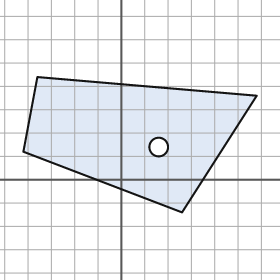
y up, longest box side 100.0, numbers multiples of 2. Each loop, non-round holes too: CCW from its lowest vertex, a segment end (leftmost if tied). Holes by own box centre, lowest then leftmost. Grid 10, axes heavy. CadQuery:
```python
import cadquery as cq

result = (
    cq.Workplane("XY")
    .moveTo(26.0, -14.0)
    .lineTo(58.0, 36.0)
    .lineTo(-36.0, 44.0)
    .lineTo(-42.0, 12.0)
    .close()
    .moveTo(16.0, 14.0)
    .circle(4.0)
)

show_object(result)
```